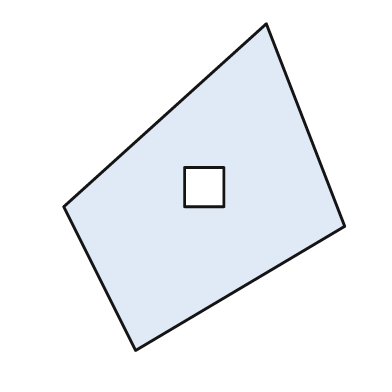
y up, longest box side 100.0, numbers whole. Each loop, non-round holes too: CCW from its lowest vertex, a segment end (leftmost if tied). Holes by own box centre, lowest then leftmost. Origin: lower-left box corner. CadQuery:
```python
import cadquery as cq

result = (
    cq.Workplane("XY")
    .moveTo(22.0, 0.0)
    .lineTo(86.0, 38.0)
    .lineTo(62.0, 100.0)
    .lineTo(0.0, 44.0)
    .close()
    .moveTo(37.0, 44.0)
    .lineTo(49.0, 44.0)
    .lineTo(49.0, 56.0)
    .lineTo(37.0, 56.0)
    .close()
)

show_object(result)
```